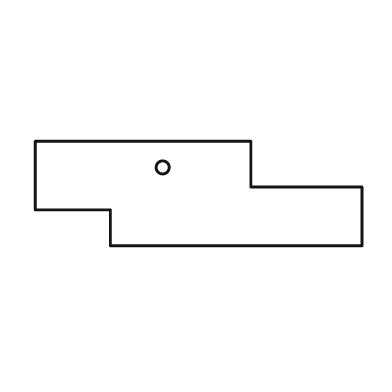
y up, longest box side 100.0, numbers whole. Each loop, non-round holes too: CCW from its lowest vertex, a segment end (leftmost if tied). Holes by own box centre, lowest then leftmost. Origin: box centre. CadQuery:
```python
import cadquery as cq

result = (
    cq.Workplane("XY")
    .moveTo(-27.0, -16.0)
    .lineTo(50.0, -16.0)
    .lineTo(50.0, 2.0)
    .lineTo(16.0, 2.0)
    .lineTo(16.0, 16.0)
    .lineTo(-50.0, 16.0)
    .lineTo(-50.0, -5.0)
    .lineTo(-27.0, -5.0)
    .close()
    .moveTo(-11.0, 8.0)
    .circle(2.0)
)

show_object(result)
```